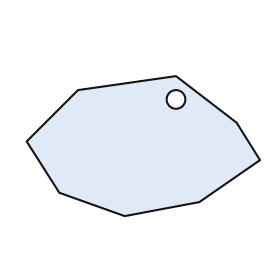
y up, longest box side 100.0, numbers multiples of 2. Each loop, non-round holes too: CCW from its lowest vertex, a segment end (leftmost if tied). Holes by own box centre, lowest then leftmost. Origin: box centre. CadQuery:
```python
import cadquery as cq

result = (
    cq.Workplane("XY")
    .moveTo(-8.0, -30.0)
    .lineTo(24.0, -24.0)
    .lineTo(50.0, -6.0)
    .lineTo(40.0, 10.0)
    .lineTo(14.0, 30.0)
    .lineTo(-28.0, 24.0)
    .lineTo(-50.0, 2.0)
    .lineTo(-36.0, -20.0)
    .close()
    .moveTo(14.0, 20.0)
    .circle(4.0)
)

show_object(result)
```